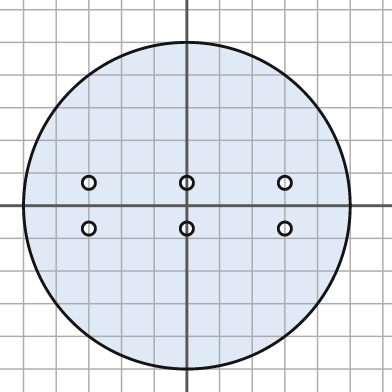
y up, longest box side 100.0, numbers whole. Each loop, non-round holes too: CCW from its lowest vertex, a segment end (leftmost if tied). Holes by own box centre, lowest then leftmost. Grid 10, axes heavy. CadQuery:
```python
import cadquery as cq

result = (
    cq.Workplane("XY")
    .moveTo(0.0, 0.0)
    .circle(50.0)
    .moveTo(-30.0, -7.0)
    .circle(2.0)
    .moveTo(0.0, -7.0)
    .circle(2.0)
    .moveTo(30.0, -7.0)
    .circle(2.0)
    .moveTo(-30.0, 7.0)
    .circle(2.0)
    .moveTo(0.0, 7.0)
    .circle(2.0)
    .moveTo(30.0, 7.0)
    .circle(2.0)
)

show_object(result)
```